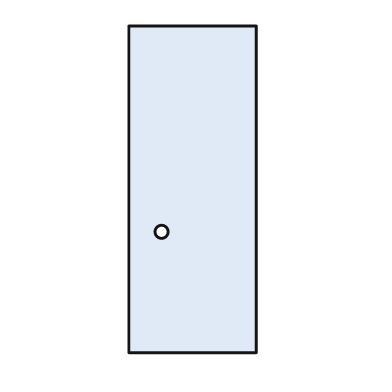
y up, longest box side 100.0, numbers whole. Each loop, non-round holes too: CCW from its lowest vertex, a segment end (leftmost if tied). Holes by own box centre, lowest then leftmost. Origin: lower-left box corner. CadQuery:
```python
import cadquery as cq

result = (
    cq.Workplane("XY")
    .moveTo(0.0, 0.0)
    .lineTo(39.0, 0.0)
    .lineTo(39.0, 100.0)
    .lineTo(0.0, 100.0)
    .close()
    .moveTo(10.0, 37.0)
    .circle(2.0)
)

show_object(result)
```